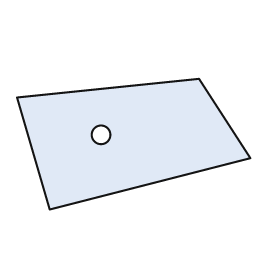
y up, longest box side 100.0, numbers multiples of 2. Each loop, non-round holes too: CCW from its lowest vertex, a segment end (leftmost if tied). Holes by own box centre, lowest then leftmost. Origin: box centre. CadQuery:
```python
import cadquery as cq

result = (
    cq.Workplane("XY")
    .moveTo(-36.0, -28.0)
    .lineTo(50.0, -6.0)
    .lineTo(28.0, 28.0)
    .lineTo(-50.0, 20.0)
    .close()
    .moveTo(-14.0, 4.0)
    .circle(4.0)
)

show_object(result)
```